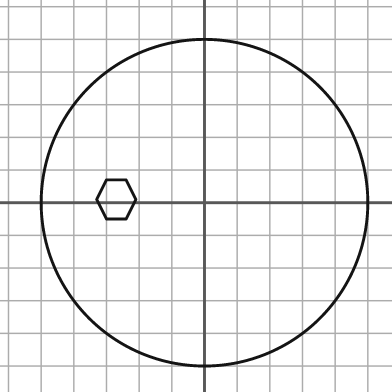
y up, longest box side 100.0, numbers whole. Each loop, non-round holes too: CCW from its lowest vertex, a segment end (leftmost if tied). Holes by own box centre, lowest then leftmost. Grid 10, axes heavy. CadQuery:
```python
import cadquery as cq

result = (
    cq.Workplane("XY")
    .moveTo(0.0, 0.0)
    .circle(50.0)
    .moveTo(-30.0, -5.0)
    .lineTo(-24.0, -5.0)
    .lineTo(-21.0, 1.0)
    .lineTo(-24.0, 7.0)
    .lineTo(-30.0, 7.0)
    .lineTo(-33.0, 1.0)
    .close()
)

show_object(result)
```